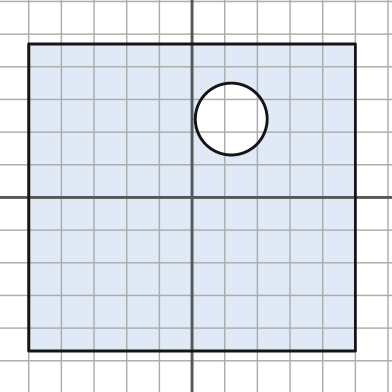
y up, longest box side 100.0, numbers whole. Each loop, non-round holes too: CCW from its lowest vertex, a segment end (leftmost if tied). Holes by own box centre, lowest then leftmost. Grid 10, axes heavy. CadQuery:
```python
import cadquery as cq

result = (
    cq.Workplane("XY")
    .moveTo(-50.0, -47.0)
    .lineTo(50.0, -47.0)
    .lineTo(50.0, 47.0)
    .lineTo(-50.0, 47.0)
    .close()
    .moveTo(12.0, 24.0)
    .circle(11.0)
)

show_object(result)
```